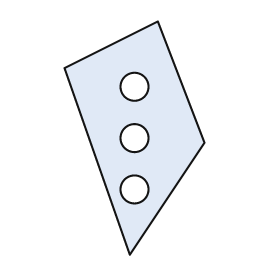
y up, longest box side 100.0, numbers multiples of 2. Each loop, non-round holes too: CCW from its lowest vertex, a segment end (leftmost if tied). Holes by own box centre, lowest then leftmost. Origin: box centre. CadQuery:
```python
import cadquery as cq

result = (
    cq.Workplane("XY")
    .moveTo(-2.0, -50.0)
    .lineTo(30.0, -2.0)
    .lineTo(10.0, 50.0)
    .lineTo(-30.0, 30.0)
    .close()
    .moveTo(0.0, -22.0)
    .circle(6.0)
    .moveTo(0.0, 0.0)
    .circle(6.0)
    .moveTo(0.0, 22.0)
    .circle(6.0)
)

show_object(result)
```